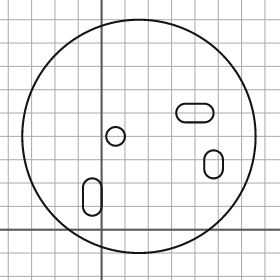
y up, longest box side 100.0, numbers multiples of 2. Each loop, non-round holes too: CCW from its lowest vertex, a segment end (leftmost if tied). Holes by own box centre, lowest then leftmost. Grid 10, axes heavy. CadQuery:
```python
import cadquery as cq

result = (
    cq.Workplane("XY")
    .moveTo(16.0, 40.0)
    .circle(50.0)
    .moveTo(-8.0, 10.0)
    .threePointArc((-4.0, 6.0), (0.0, 10.0))
    .lineTo(0.0, 18.0)
    .threePointArc((-4.0, 22.0), (-8.0, 18.0))
    .close()
    .moveTo(44.0, 26.0)
    .threePointArc((48.0, 22.0), (52.0, 26.0))
    .lineTo(52.0, 30.0)
    .threePointArc((48.0, 34.0), (44.0, 30.0))
    .close()
    .moveTo(6.0, 40.0)
    .circle(4.0)
    .moveTo(36.0, 46.0)
    .lineTo(44.0, 46.0)
    .threePointArc((48.0, 50.0), (44.0, 54.0))
    .lineTo(36.0, 54.0)
    .threePointArc((32.0, 50.0), (36.0, 46.0))
    .close()
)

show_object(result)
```